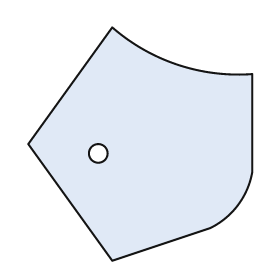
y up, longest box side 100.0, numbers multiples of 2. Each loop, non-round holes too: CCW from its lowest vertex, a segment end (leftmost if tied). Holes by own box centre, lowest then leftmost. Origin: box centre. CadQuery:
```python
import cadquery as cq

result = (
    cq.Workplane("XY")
    .moveTo(-12.0, -50.0)
    .lineTo(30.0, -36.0)
    .threePointArc((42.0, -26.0), (48.0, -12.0))
    .lineTo(48.0, 30.0)
    .threePointArc((16.0, 34.0), (-12.0, 50.0))
    .lineTo(-48.0, 0.0)
    .close()
    .moveTo(-18.0, -4.0)
    .circle(4.0)
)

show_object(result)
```